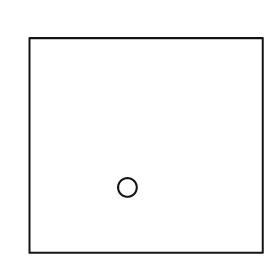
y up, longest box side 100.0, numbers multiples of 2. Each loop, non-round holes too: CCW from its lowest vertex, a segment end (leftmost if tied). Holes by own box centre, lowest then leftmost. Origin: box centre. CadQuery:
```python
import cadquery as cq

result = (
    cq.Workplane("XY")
    .moveTo(-50.0, -46.0)
    .lineTo(50.0, -46.0)
    .lineTo(50.0, 46.0)
    .lineTo(-50.0, 46.0)
    .close()
    .moveTo(-8.0, -18.0)
    .circle(4.0)
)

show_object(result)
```